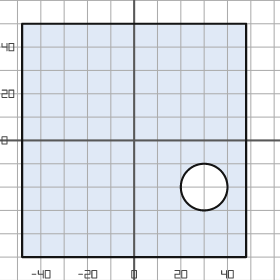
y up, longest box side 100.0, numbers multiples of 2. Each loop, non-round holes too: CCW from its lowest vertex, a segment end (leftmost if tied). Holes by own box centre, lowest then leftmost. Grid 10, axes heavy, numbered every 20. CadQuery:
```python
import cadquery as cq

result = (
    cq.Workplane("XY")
    .moveTo(-48.0, -50.0)
    .lineTo(48.0, -50.0)
    .lineTo(48.0, 50.0)
    .lineTo(-48.0, 50.0)
    .close()
    .moveTo(30.0, -20.0)
    .circle(10.0)
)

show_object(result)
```